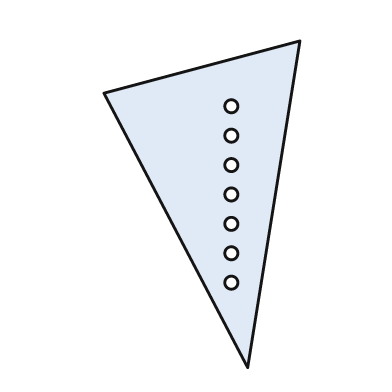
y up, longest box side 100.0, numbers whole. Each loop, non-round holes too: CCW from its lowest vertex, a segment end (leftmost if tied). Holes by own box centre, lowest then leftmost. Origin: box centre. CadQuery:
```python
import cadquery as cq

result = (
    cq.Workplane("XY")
    .moveTo(14.0, -50.0)
    .lineTo(30.0, 50.0)
    .lineTo(-30.0, 34.0)
    .close()
    .moveTo(9.0, -24.0)
    .circle(2.0)
    .moveTo(9.0, -15.0)
    .circle(2.0)
    .moveTo(9.0, -6.0)
    .circle(2.0)
    .moveTo(9.0, 3.0)
    .circle(2.0)
    .moveTo(9.0, 12.0)
    .circle(2.0)
    .moveTo(9.0, 21.0)
    .circle(2.0)
    .moveTo(9.0, 30.0)
    .circle(2.0)
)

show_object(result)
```